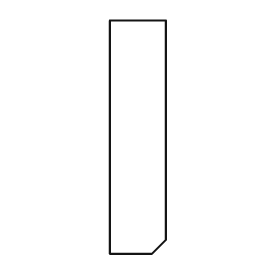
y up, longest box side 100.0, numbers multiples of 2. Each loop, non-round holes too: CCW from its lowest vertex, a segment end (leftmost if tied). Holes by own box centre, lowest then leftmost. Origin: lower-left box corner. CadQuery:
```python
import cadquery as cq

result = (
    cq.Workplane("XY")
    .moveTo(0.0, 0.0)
    .lineTo(18.0, 0.0)
    .lineTo(24.0, 6.0)
    .lineTo(24.0, 100.0)
    .lineTo(0.0, 100.0)
    .close()
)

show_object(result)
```